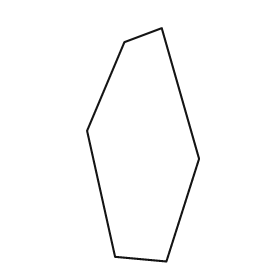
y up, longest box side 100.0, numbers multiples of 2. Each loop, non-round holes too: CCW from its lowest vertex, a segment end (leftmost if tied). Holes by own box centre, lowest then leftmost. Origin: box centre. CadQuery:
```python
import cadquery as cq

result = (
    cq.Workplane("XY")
    .moveTo(10.0, -50.0)
    .lineTo(24.0, -6.0)
    .lineTo(8.0, 50.0)
    .lineTo(-8.0, 44.0)
    .lineTo(-24.0, 6.0)
    .lineTo(-12.0, -48.0)
    .close()
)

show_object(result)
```